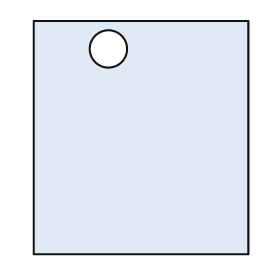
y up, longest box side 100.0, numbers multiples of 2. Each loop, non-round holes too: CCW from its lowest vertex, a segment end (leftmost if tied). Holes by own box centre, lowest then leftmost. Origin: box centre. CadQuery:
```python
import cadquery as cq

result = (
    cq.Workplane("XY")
    .moveTo(-46.0, -50.0)
    .lineTo(46.0, -50.0)
    .lineTo(46.0, 50.0)
    .lineTo(-46.0, 50.0)
    .close()
    .moveTo(-14.0, 38.0)
    .circle(8.0)
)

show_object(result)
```